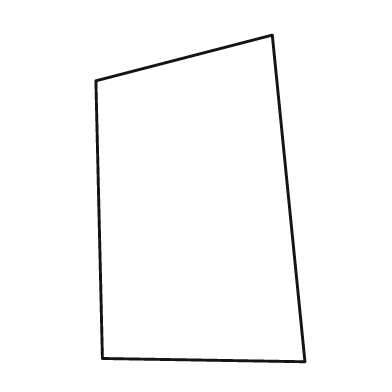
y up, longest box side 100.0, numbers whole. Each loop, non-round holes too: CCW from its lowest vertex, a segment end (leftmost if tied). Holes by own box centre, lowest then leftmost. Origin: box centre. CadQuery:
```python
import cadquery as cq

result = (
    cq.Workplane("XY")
    .moveTo(32.0, -50.0)
    .lineTo(22.0, 50.0)
    .lineTo(-32.0, 36.0)
    .lineTo(-30.0, -49.0)
    .close()
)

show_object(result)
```